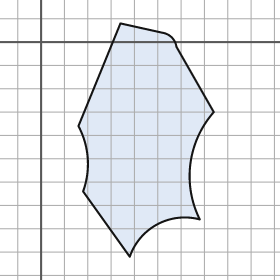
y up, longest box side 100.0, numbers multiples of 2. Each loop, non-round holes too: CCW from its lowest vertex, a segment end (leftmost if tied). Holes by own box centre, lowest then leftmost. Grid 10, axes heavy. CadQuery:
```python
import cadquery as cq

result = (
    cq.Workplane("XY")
    .moveTo(38.0, -92.0)
    .threePointArc((50.0, -78.0), (68.0, -76.0))
    .threePointArc((64.0, -52.0), (74.0, -30.0))
    .lineTo(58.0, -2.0)
    .threePointArc((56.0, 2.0), (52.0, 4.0))
    .lineTo(34.0, 8.0)
    .lineTo(16.0, -36.0)
    .threePointArc((20.0, -50.0), (18.0, -64.0))
    .close()
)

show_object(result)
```